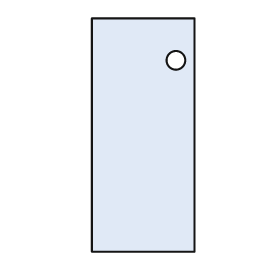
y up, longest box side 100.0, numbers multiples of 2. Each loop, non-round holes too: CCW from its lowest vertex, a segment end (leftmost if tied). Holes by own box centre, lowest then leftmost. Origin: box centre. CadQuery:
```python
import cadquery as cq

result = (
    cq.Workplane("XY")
    .moveTo(-22.0, -50.0)
    .lineTo(22.0, -50.0)
    .lineTo(22.0, 50.0)
    .lineTo(-22.0, 50.0)
    .close()
    .moveTo(14.0, 32.0)
    .circle(4.0)
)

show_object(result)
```